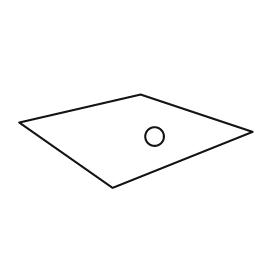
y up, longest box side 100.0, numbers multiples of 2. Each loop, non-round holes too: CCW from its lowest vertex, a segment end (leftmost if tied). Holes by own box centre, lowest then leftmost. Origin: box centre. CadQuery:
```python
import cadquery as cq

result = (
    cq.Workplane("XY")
    .moveTo(-10.0, -20.0)
    .lineTo(50.0, 4.0)
    .lineTo(2.0, 20.0)
    .lineTo(-50.0, 8.0)
    .close()
    .moveTo(8.0, 2.0)
    .circle(4.0)
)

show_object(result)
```